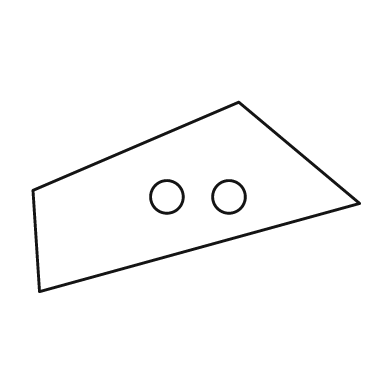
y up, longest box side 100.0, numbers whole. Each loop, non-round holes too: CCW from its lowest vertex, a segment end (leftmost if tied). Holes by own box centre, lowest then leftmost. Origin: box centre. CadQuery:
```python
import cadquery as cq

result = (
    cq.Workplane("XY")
    .moveTo(-48.0, -29.0)
    .lineTo(50.0, -2.0)
    .lineTo(13.0, 29.0)
    .lineTo(-50.0, 2.0)
    .close()
    .moveTo(-9.0, 0.0)
    .circle(5.0)
    .moveTo(10.0, 0.0)
    .circle(5.0)
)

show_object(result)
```